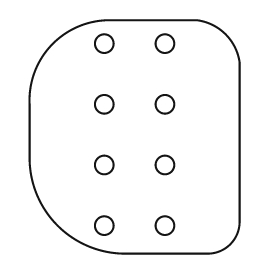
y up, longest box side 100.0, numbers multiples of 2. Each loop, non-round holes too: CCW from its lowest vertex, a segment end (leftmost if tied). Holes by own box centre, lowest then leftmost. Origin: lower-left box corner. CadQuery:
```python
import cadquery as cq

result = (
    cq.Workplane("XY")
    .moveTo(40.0, 0.0)
    .lineTo(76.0, 0.0)
    .threePointArc((86.0, 4.0), (90.0, 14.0))
    .lineTo(90.0, 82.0)
    .threePointArc((84.0, 94.0), (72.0, 100.0))
    .lineTo(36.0, 100.0)
    .threePointArc((10.0, 90.0), (0.0, 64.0))
    .lineTo(0.0, 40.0)
    .threePointArc((12.0, 12.0), (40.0, 0.0))
    .close()
    .moveTo(32.0, 12.0)
    .circle(4.0)
    .moveTo(58.0, 12.0)
    .circle(4.0)
    .moveTo(32.0, 38.0)
    .circle(4.0)
    .moveTo(58.0, 38.0)
    .circle(4.0)
    .moveTo(32.0, 64.0)
    .circle(4.0)
    .moveTo(58.0, 64.0)
    .circle(4.0)
    .moveTo(32.0, 90.0)
    .circle(4.0)
    .moveTo(58.0, 90.0)
    .circle(4.0)
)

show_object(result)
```